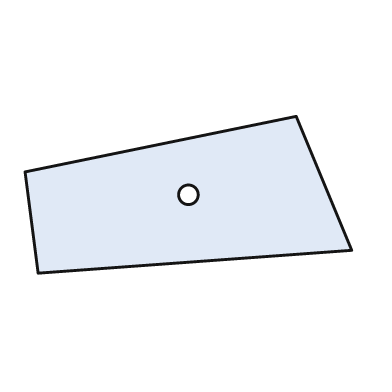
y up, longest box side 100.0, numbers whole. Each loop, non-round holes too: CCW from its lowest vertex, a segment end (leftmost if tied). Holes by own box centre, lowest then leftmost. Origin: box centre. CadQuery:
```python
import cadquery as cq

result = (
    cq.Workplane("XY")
    .moveTo(-46.0, -24.0)
    .lineTo(50.0, -17.0)
    .lineTo(33.0, 24.0)
    .lineTo(-50.0, 7.0)
    .close()
    .moveTo(0.0, 0.0)
    .circle(3.0)
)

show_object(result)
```